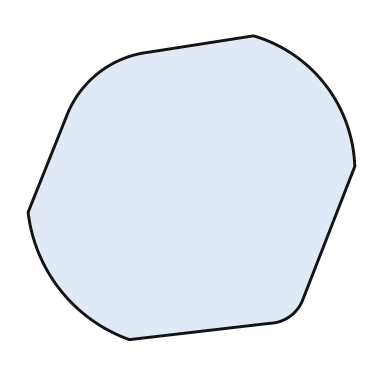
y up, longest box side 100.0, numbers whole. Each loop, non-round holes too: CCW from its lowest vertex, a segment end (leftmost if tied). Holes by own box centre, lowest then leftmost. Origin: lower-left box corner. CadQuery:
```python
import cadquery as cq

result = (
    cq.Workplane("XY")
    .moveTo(31.0, 0.0)
    .lineTo(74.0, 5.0)
    .threePointArc((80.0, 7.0), (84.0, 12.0))
    .lineTo(100.0, 53.0)
    .threePointArc((91.0, 78.0), (69.0, 93.0))
    .lineTo(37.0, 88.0)
    .threePointArc((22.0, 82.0), (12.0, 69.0))
    .lineTo(0.0, 39.0)
    .threePointArc((10.0, 15.0), (31.0, 0.0))
    .close()
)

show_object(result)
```